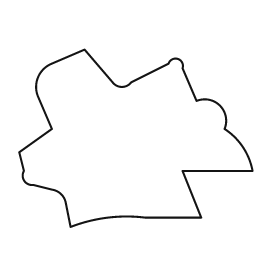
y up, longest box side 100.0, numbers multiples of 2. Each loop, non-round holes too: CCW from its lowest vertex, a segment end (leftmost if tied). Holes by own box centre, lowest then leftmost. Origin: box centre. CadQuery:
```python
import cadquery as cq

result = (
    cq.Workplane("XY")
    .moveTo(-28.0, -38.0)
    .threePointArc((-12.0, -34.0), (4.0, -34.0))
    .lineTo(28.0, -34.0)
    .lineTo(20.0, -14.0)
    .lineTo(50.0, -14.0)
    .threePointArc((46.0, -4.0), (38.0, 4.0))
    .threePointArc((36.0, 14.0), (26.0, 16.0))
    .lineTo(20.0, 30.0)
    .threePointArc((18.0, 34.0), (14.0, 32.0))
    .lineTo(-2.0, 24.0)
    .threePointArc((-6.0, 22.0), (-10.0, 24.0))
    .lineTo(-22.0, 38.0)
    .lineTo(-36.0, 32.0)
    .threePointArc((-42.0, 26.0), (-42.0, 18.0))
    .lineTo(-36.0, 4.0)
    .lineTo(-50.0, -6.0)
    .lineTo(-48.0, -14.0)
    .threePointArc((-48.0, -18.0), (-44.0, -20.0))
    .lineTo(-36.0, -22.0)
    .threePointArc((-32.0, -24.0), (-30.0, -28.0))
    .close()
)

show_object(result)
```